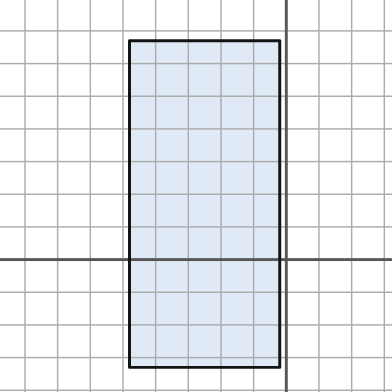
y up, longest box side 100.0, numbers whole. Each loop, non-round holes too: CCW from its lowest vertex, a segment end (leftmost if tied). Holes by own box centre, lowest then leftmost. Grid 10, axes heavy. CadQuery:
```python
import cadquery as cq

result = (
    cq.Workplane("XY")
    .moveTo(-48.0, -33.0)
    .lineTo(-2.0, -33.0)
    .lineTo(-2.0, 67.0)
    .lineTo(-48.0, 67.0)
    .close()
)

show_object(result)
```